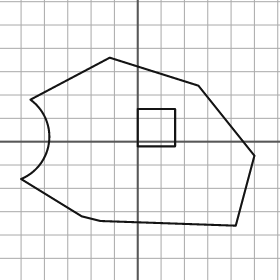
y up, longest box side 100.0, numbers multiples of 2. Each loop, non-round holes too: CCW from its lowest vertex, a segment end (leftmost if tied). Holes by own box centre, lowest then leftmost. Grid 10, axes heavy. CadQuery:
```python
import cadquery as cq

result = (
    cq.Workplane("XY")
    .moveTo(42.0, -36.0)
    .lineTo(50.0, -6.0)
    .lineTo(26.0, 24.0)
    .lineTo(-12.0, 36.0)
    .lineTo(-46.0, 18.0)
    .threePointArc((-38.0, 0.0), (-50.0, -16.0))
    .lineTo(-24.0, -32.0)
    .lineTo(-16.0, -34.0)
    .close()
    .moveTo(0.0, -2.0)
    .lineTo(16.0, -2.0)
    .lineTo(16.0, 14.0)
    .lineTo(0.0, 14.0)
    .close()
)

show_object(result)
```